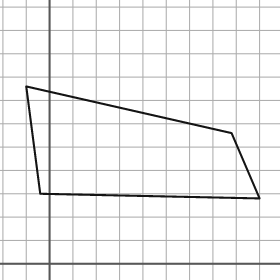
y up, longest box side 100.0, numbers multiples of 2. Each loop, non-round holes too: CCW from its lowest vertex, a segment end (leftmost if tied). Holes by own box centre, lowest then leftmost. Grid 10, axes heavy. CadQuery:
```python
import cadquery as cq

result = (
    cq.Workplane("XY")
    .moveTo(90.0, 28.0)
    .lineTo(78.0, 56.0)
    .lineTo(-10.0, 76.0)
    .lineTo(-4.0, 30.0)
    .close()
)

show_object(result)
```